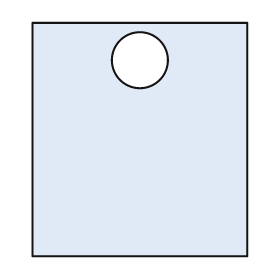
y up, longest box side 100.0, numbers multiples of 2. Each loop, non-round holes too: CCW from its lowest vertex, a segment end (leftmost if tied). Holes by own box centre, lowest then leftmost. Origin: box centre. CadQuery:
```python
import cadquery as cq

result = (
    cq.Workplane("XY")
    .moveTo(-46.0, -50.0)
    .lineTo(46.0, -50.0)
    .lineTo(46.0, 50.0)
    .lineTo(-46.0, 50.0)
    .close()
    .moveTo(0.0, 34.0)
    .circle(12.0)
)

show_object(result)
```